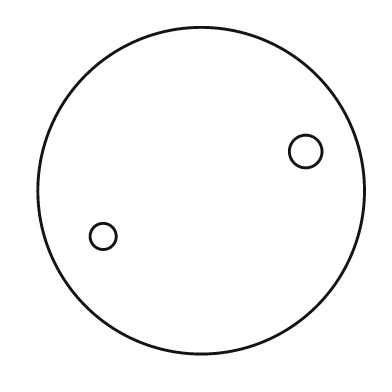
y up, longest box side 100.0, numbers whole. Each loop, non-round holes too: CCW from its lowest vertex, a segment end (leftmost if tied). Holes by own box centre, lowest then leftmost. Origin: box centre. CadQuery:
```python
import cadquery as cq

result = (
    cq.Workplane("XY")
    .moveTo(0.0, 0.0)
    .circle(50.0)
    .moveTo(-30.0, -14.0)
    .circle(4.0)
    .moveTo(32.0, 12.0)
    .circle(5.0)
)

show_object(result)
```